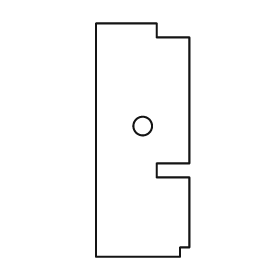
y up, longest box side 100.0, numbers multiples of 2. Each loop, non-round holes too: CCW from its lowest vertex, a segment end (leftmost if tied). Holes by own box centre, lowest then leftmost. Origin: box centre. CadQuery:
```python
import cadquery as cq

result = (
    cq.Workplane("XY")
    .moveTo(-20.0, -50.0)
    .lineTo(16.0, -50.0)
    .lineTo(16.0, -46.0)
    .lineTo(20.0, -46.0)
    .lineTo(20.0, -16.0)
    .lineTo(6.0, -16.0)
    .lineTo(6.0, -10.0)
    .lineTo(20.0, -10.0)
    .lineTo(20.0, 44.0)
    .lineTo(6.0, 44.0)
    .lineTo(6.0, 50.0)
    .lineTo(-20.0, 50.0)
    .close()
    .moveTo(0.0, 6.0)
    .circle(4.0)
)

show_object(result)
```